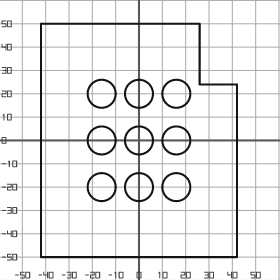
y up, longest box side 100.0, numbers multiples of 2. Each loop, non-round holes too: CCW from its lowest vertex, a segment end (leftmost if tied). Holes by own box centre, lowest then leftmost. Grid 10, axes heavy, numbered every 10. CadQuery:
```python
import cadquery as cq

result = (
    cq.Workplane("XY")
    .moveTo(-42.0, -50.0)
    .lineTo(42.0, -50.0)
    .lineTo(42.0, 24.0)
    .lineTo(26.0, 24.0)
    .lineTo(26.0, 50.0)
    .lineTo(-42.0, 50.0)
    .close()
    .moveTo(-16.0, -20.0)
    .circle(6.0)
    .moveTo(0.0, -20.0)
    .circle(6.0)
    .moveTo(16.0, -20.0)
    .circle(6.0)
    .moveTo(-16.0, 0.0)
    .circle(6.0)
    .moveTo(0.0, 0.0)
    .circle(6.0)
    .moveTo(16.0, 0.0)
    .circle(6.0)
    .moveTo(-16.0, 20.0)
    .circle(6.0)
    .moveTo(0.0, 20.0)
    .circle(6.0)
    .moveTo(16.0, 20.0)
    .circle(6.0)
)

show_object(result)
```